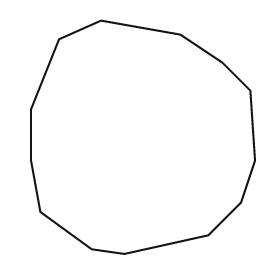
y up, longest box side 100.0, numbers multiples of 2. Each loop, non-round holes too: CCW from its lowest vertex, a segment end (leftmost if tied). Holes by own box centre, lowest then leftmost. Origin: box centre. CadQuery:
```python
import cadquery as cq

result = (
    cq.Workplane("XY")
    .moveTo(-8.0, -50.0)
    .lineTo(28.0, -42.0)
    .lineTo(42.0, -28.0)
    .lineTo(48.0, -10.0)
    .lineTo(46.0, 20.0)
    .lineTo(34.0, 32.0)
    .lineTo(16.0, 44.0)
    .lineTo(-18.0, 50.0)
    .lineTo(-36.0, 42.0)
    .lineTo(-48.0, 12.0)
    .lineTo(-48.0, -10.0)
    .lineTo(-44.0, -32.0)
    .lineTo(-22.0, -48.0)
    .close()
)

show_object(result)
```